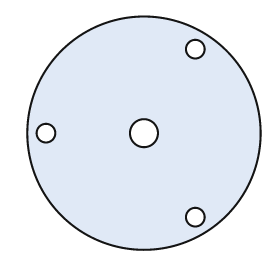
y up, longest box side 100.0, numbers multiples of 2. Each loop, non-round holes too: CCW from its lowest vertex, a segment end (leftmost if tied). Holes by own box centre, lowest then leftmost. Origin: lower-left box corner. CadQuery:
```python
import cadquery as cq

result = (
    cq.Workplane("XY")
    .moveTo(50.0, 50.0)
    .circle(50.0)
    .moveTo(72.0, 14.0)
    .circle(4.0)
    .moveTo(8.0, 50.0)
    .circle(4.0)
    .moveTo(50.0, 50.0)
    .circle(6.0)
    .moveTo(72.0, 86.0)
    .circle(4.0)
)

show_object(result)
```